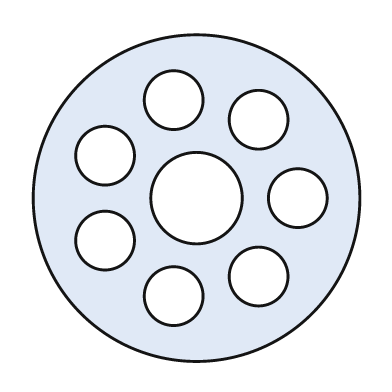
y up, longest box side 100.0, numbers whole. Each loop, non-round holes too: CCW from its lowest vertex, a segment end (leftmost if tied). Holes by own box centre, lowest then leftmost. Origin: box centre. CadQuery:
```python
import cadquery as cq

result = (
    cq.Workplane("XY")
    .moveTo(0.0, 0.0)
    .circle(50.0)
    .moveTo(-7.0, -30.0)
    .circle(9.0)
    .moveTo(19.0, -24.0)
    .circle(9.0)
    .moveTo(-28.0, -13.0)
    .circle(9.0)
    .moveTo(0.0, 0.0)
    .circle(14.0)
    .moveTo(31.0, 0.0)
    .circle(9.0)
    .moveTo(-28.0, 13.0)
    .circle(9.0)
    .moveTo(19.0, 24.0)
    .circle(9.0)
    .moveTo(-7.0, 30.0)
    .circle(9.0)
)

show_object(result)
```